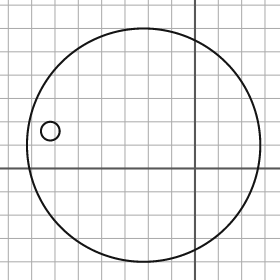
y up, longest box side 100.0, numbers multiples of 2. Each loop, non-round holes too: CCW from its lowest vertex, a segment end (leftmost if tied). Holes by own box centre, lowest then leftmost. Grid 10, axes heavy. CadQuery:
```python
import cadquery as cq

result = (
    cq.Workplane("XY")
    .moveTo(-22.0, 10.0)
    .circle(50.0)
    .moveTo(-62.0, 16.0)
    .circle(4.0)
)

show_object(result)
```